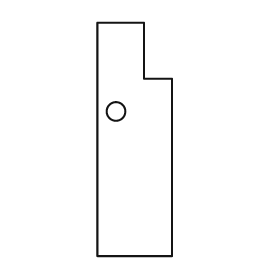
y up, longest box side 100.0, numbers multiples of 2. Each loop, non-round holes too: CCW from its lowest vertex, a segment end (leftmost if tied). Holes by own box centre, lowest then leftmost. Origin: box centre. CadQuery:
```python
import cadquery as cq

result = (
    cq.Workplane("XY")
    .moveTo(-16.0, -50.0)
    .lineTo(16.0, -50.0)
    .lineTo(16.0, 26.0)
    .lineTo(4.0, 26.0)
    .lineTo(4.0, 50.0)
    .lineTo(-16.0, 50.0)
    .close()
    .moveTo(-8.0, 12.0)
    .circle(4.0)
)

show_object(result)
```